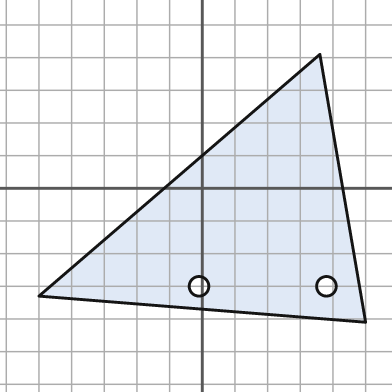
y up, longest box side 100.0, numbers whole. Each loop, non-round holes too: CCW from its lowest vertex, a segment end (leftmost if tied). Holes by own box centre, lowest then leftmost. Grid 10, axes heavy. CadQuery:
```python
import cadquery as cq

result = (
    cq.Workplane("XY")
    .moveTo(50.0, -41.0)
    .lineTo(36.0, 41.0)
    .lineTo(-50.0, -33.0)
    .close()
    .moveTo(-1.0, -30.0)
    .circle(3.0)
    .moveTo(38.0, -30.0)
    .circle(3.0)
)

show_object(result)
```